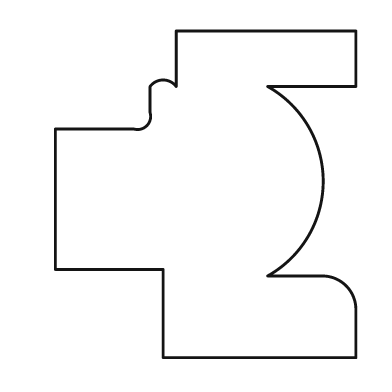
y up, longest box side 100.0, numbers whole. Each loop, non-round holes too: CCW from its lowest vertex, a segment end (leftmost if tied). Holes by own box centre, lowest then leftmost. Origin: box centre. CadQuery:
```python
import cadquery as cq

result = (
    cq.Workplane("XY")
    .moveTo(-13.0, -50.0)
    .lineTo(46.0, -50.0)
    .lineTo(46.0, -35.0)
    .threePointArc((43.0, -28.0), (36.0, -25.0))
    .lineTo(19.0, -25.0)
    .threePointArc((36.0, 4.0), (19.0, 33.0))
    .lineTo(46.0, 33.0)
    .lineTo(46.0, 50.0)
    .lineTo(-9.0, 50.0)
    .lineTo(-9.0, 33.0)
    .threePointArc((-13.0, 35.0), (-17.0, 33.0))
    .lineTo(-17.0, 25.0)
    .threePointArc((-18.0, 21.0), (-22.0, 20.0))
    .lineTo(-46.0, 20.0)
    .lineTo(-46.0, -23.0)
    .lineTo(-13.0, -23.0)
    .close()
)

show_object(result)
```